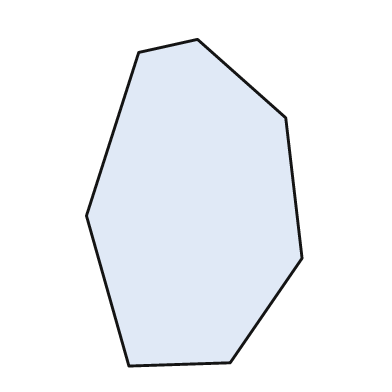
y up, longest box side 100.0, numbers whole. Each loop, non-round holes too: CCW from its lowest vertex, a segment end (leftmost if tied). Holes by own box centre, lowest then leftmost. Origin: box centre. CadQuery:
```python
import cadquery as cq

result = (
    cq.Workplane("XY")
    .moveTo(-20.0, -50.0)
    .lineTo(11.0, -49.0)
    .lineTo(33.0, -17.0)
    .lineTo(28.0, 26.0)
    .lineTo(1.0, 50.0)
    .lineTo(-17.0, 46.0)
    .lineTo(-33.0, -4.0)
    .close()
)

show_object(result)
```